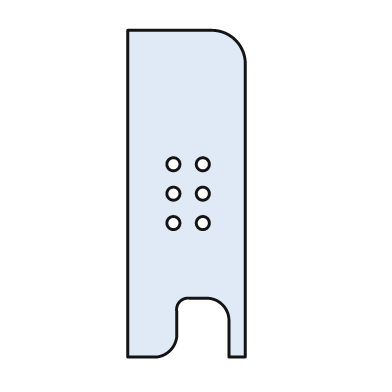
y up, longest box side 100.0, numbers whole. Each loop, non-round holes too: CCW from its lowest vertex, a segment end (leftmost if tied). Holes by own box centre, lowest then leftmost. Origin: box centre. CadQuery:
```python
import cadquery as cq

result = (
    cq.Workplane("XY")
    .moveTo(-18.0, -50.0)
    .lineTo(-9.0, -50.0)
    .threePointArc((-5.0, -48.0), (-3.0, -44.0))
    .lineTo(-3.0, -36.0)
    .threePointArc((-2.0, -33.0), (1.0, -32.0))
    .lineTo(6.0, -32.0)
    .threePointArc((11.0, -34.0), (13.0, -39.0))
    .lineTo(13.0, -50.0)
    .lineTo(18.0, -50.0)
    .lineTo(18.0, 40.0)
    .threePointArc((15.0, 47.0), (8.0, 50.0))
    .lineTo(-18.0, 50.0)
    .close()
    .moveTo(-4.0, -9.0)
    .circle(2.0)
    .moveTo(5.0, -9.0)
    .circle(2.0)
    .moveTo(-4.0, 0.0)
    .circle(2.0)
    .moveTo(5.0, 0.0)
    .circle(2.0)
    .moveTo(-4.0, 9.0)
    .circle(2.0)
    .moveTo(5.0, 9.0)
    .circle(2.0)
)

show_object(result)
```